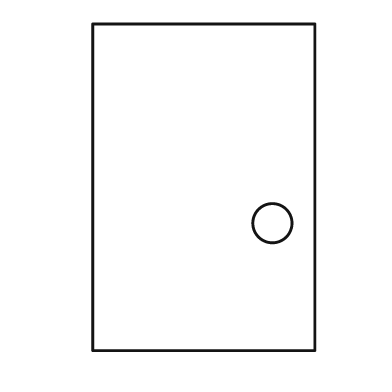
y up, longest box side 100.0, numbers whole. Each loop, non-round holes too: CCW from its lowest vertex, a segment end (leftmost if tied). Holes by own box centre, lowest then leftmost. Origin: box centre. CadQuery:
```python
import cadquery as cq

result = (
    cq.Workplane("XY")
    .moveTo(-34.0, -50.0)
    .lineTo(34.0, -50.0)
    .lineTo(34.0, 50.0)
    .lineTo(-34.0, 50.0)
    .close()
    .moveTo(21.0, -11.0)
    .circle(6.0)
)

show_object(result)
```